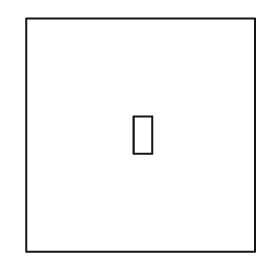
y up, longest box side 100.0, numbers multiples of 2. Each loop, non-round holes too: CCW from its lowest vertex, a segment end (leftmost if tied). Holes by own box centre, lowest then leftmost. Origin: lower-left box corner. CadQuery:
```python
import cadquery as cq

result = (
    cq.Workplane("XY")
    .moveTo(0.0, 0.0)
    .lineTo(98.0, 0.0)
    .lineTo(98.0, 100.0)
    .lineTo(0.0, 100.0)
    .close()
    .moveTo(46.0, 42.0)
    .lineTo(54.0, 42.0)
    .lineTo(54.0, 58.0)
    .lineTo(46.0, 58.0)
    .close()
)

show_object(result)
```